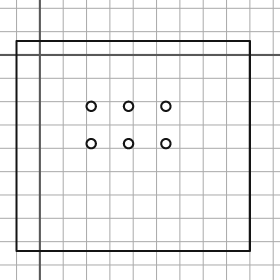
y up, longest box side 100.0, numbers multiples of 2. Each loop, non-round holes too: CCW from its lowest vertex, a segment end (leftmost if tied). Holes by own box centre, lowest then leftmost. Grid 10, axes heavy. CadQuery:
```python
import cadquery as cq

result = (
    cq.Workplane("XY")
    .moveTo(-10.0, -84.0)
    .lineTo(90.0, -84.0)
    .lineTo(90.0, 6.0)
    .lineTo(-10.0, 6.0)
    .close()
    .moveTo(22.0, -38.0)
    .circle(2.0)
    .moveTo(38.0, -38.0)
    .circle(2.0)
    .moveTo(54.0, -38.0)
    .circle(2.0)
    .moveTo(22.0, -22.0)
    .circle(2.0)
    .moveTo(38.0, -22.0)
    .circle(2.0)
    .moveTo(54.0, -22.0)
    .circle(2.0)
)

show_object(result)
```